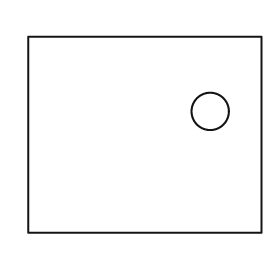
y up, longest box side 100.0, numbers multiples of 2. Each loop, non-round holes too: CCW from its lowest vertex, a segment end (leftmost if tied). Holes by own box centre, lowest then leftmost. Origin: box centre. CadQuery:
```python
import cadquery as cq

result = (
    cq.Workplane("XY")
    .moveTo(-50.0, -42.0)
    .lineTo(50.0, -42.0)
    .lineTo(50.0, 42.0)
    .lineTo(-50.0, 42.0)
    .close()
    .moveTo(28.0, 10.0)
    .circle(8.0)
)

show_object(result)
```